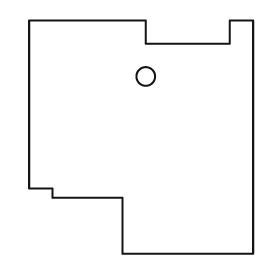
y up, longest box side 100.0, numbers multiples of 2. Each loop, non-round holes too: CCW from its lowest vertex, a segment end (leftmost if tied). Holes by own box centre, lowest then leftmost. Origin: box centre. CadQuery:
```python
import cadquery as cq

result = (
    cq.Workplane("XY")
    .moveTo(-8.0, -50.0)
    .lineTo(48.0, -50.0)
    .lineTo(48.0, 50.0)
    .lineTo(38.0, 50.0)
    .lineTo(38.0, 40.0)
    .lineTo(2.0, 40.0)
    .lineTo(2.0, 50.0)
    .lineTo(-48.0, 50.0)
    .lineTo(-48.0, -22.0)
    .lineTo(-38.0, -22.0)
    .lineTo(-38.0, -26.0)
    .lineTo(-8.0, -26.0)
    .close()
    .moveTo(2.0, 26.0)
    .circle(4.0)
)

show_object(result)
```